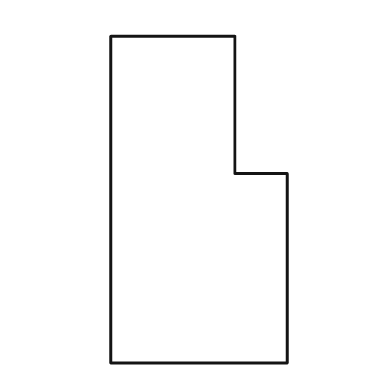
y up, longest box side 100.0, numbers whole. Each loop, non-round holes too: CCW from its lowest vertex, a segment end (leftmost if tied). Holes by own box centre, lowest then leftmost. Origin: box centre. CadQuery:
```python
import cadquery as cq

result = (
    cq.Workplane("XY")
    .moveTo(-27.0, -50.0)
    .lineTo(27.0, -50.0)
    .lineTo(27.0, 8.0)
    .lineTo(11.0, 8.0)
    .lineTo(11.0, 50.0)
    .lineTo(-27.0, 50.0)
    .close()
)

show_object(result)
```